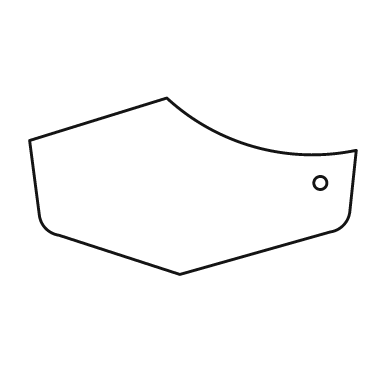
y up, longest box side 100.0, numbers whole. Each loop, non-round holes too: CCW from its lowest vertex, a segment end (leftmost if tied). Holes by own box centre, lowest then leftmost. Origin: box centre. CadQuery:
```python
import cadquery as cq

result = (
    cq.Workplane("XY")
    .moveTo(-4.0, -27.0)
    .lineTo(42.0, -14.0)
    .threePointArc((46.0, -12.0), (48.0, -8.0))
    .lineTo(50.0, 11.0)
    .threePointArc((19.0, 12.0), (-8.0, 27.0))
    .lineTo(-50.0, 14.0)
    .lineTo(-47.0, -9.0)
    .threePointArc((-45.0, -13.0), (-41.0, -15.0))
    .close()
    .moveTo(39.0, 1.0)
    .circle(2.0)
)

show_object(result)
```